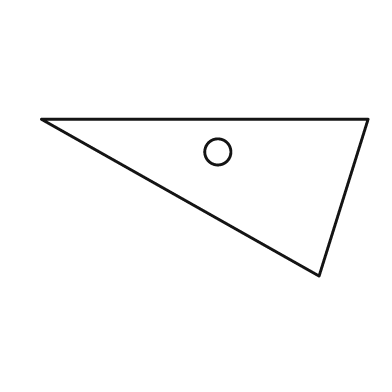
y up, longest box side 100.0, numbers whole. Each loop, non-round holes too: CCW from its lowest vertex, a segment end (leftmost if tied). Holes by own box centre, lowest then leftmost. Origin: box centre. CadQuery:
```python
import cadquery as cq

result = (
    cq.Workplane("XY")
    .moveTo(35.0, -24.0)
    .lineTo(50.0, 24.0)
    .lineTo(-50.0, 24.0)
    .close()
    .moveTo(4.0, 14.0)
    .circle(4.0)
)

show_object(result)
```